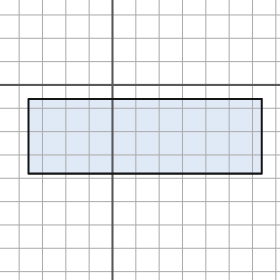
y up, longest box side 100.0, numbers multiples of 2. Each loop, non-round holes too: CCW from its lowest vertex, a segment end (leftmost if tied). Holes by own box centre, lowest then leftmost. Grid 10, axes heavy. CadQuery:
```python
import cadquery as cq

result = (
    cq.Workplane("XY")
    .moveTo(-36.0, -38.0)
    .lineTo(64.0, -38.0)
    .lineTo(64.0, -6.0)
    .lineTo(-36.0, -6.0)
    .close()
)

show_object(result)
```